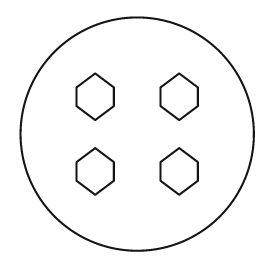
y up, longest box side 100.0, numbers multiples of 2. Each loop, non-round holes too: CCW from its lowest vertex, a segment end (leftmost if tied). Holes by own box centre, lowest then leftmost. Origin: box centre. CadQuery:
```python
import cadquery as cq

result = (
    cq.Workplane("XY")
    .moveTo(0.0, 0.0)
    .circle(50.0)
    .moveTo(-18.0, -26.0)
    .lineTo(-10.0, -20.0)
    .lineTo(-10.0, -12.0)
    .lineTo(-18.0, -6.0)
    .lineTo(-26.0, -12.0)
    .lineTo(-26.0, -20.0)
    .close()
    .moveTo(18.0, -26.0)
    .lineTo(26.0, -20.0)
    .lineTo(26.0, -12.0)
    .lineTo(18.0, -6.0)
    .lineTo(10.0, -12.0)
    .lineTo(10.0, -20.0)
    .close()
    .moveTo(-18.0, 6.0)
    .lineTo(-10.0, 12.0)
    .lineTo(-10.0, 20.0)
    .lineTo(-18.0, 26.0)
    .lineTo(-26.0, 20.0)
    .lineTo(-26.0, 12.0)
    .close()
    .moveTo(18.0, 6.0)
    .lineTo(26.0, 12.0)
    .lineTo(26.0, 20.0)
    .lineTo(18.0, 26.0)
    .lineTo(10.0, 20.0)
    .lineTo(10.0, 12.0)
    .close()
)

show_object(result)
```